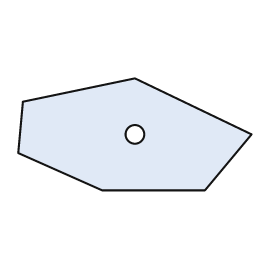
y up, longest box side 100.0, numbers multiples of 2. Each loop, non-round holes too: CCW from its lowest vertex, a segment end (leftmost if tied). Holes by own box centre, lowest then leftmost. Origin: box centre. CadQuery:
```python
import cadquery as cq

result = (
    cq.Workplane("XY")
    .moveTo(-14.0, -24.0)
    .lineTo(30.0, -24.0)
    .lineTo(50.0, 0.0)
    .lineTo(0.0, 24.0)
    .lineTo(-48.0, 14.0)
    .lineTo(-50.0, -8.0)
    .close()
    .moveTo(0.0, 0.0)
    .circle(4.0)
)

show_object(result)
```